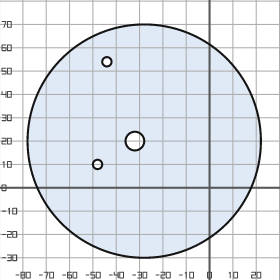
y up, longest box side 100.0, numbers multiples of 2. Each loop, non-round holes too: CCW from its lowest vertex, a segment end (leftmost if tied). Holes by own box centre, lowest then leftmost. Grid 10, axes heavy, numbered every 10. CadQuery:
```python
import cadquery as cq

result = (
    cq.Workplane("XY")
    .moveTo(-28.0, 20.0)
    .circle(50.0)
    .moveTo(-48.0, 10.0)
    .circle(2.0)
    .moveTo(-32.0, 20.0)
    .circle(4.0)
    .moveTo(-44.0, 54.0)
    .circle(2.0)
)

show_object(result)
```